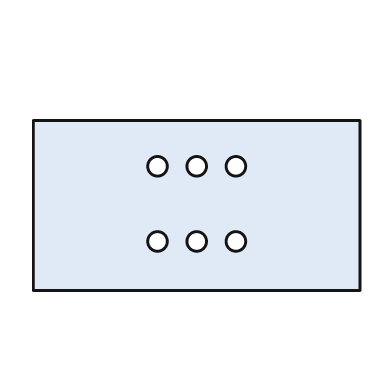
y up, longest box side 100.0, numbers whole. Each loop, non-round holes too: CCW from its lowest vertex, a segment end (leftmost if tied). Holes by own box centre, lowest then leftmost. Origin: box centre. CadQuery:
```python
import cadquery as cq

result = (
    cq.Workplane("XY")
    .moveTo(-50.0, -26.0)
    .lineTo(50.0, -26.0)
    .lineTo(50.0, 26.0)
    .lineTo(-50.0, 26.0)
    .close()
    .moveTo(-12.0, -11.0)
    .circle(3.0)
    .moveTo(0.0, -11.0)
    .circle(3.0)
    .moveTo(12.0, -11.0)
    .circle(3.0)
    .moveTo(-12.0, 12.0)
    .circle(3.0)
    .moveTo(0.0, 12.0)
    .circle(3.0)
    .moveTo(12.0, 12.0)
    .circle(3.0)
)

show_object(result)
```